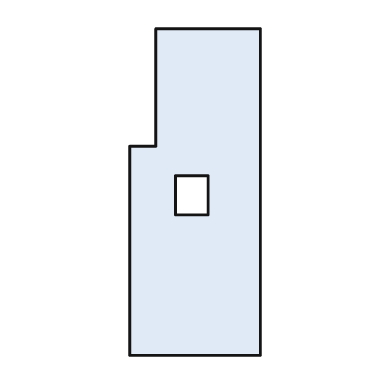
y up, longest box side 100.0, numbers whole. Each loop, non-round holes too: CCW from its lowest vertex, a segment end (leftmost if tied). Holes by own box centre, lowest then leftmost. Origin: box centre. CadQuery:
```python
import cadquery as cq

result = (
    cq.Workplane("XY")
    .moveTo(-20.0, -50.0)
    .lineTo(20.0, -50.0)
    .lineTo(20.0, 50.0)
    .lineTo(-12.0, 50.0)
    .lineTo(-12.0, 14.0)
    .lineTo(-20.0, 14.0)
    .close()
    .moveTo(-6.0, -7.0)
    .lineTo(4.0, -7.0)
    .lineTo(4.0, 5.0)
    .lineTo(-6.0, 5.0)
    .close()
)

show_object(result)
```